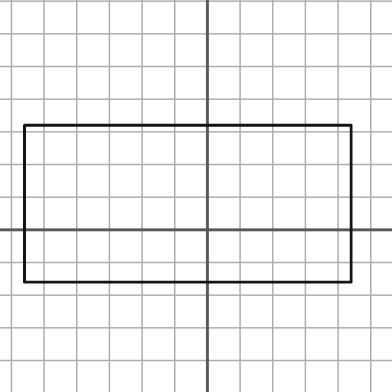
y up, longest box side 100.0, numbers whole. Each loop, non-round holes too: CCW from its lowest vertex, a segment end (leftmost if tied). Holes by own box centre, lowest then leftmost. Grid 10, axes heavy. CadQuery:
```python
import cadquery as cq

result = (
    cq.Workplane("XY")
    .moveTo(-56.0, -16.0)
    .lineTo(44.0, -16.0)
    .lineTo(44.0, 32.0)
    .lineTo(-56.0, 32.0)
    .close()
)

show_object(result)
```